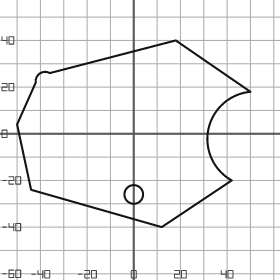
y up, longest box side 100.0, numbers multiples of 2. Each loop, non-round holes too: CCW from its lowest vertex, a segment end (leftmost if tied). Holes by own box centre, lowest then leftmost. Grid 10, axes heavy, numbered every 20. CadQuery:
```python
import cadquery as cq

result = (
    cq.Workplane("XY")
    .moveTo(12.0, -40.0)
    .lineTo(42.0, -20.0)
    .threePointArc((32.0, 2.0), (50.0, 18.0))
    .lineTo(18.0, 40.0)
    .lineTo(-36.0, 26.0)
    .threePointArc((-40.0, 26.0), (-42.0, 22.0))
    .lineTo(-50.0, 4.0)
    .lineTo(-44.0, -24.0)
    .close()
    .moveTo(0.0, -26.0)
    .circle(4.0)
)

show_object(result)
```